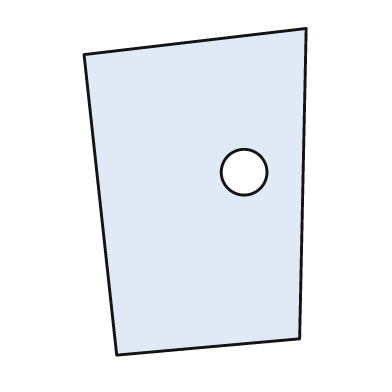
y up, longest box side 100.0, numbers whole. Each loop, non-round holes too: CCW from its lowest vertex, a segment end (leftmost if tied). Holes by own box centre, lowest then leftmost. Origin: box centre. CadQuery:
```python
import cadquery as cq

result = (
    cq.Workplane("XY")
    .moveTo(-24.0, -50.0)
    .lineTo(32.0, -45.0)
    .lineTo(34.0, 50.0)
    .lineTo(-34.0, 42.0)
    .close()
    .moveTo(15.0, 6.0)
    .circle(7.0)
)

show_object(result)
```